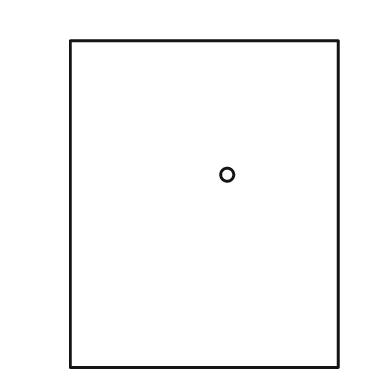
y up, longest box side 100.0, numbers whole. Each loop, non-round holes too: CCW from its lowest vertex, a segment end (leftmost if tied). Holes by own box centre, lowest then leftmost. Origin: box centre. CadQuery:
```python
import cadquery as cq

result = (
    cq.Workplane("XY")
    .moveTo(-41.0, -50.0)
    .lineTo(41.0, -50.0)
    .lineTo(41.0, 50.0)
    .lineTo(-41.0, 50.0)
    .close()
    .moveTo(7.0, 9.0)
    .circle(2.0)
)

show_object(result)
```